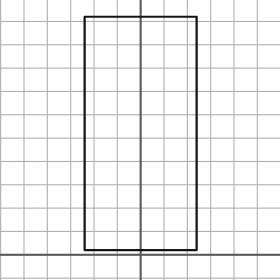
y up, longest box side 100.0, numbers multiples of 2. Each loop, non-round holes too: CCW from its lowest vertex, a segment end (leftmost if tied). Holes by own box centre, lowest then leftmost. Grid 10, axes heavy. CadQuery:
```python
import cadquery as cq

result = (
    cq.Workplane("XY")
    .moveTo(-24.0, 2.0)
    .lineTo(24.0, 2.0)
    .lineTo(24.0, 102.0)
    .lineTo(-24.0, 102.0)
    .close()
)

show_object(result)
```